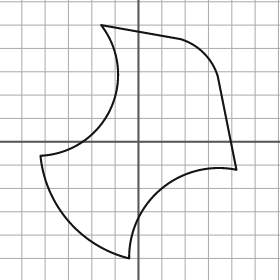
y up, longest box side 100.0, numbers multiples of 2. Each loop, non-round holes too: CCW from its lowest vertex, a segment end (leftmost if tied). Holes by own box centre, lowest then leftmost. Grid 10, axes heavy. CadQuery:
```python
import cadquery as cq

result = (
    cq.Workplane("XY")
    .moveTo(-4.0, -50.0)
    .threePointArc((10.0, -20.0), (42.0, -12.0))
    .lineTo(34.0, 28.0)
    .threePointArc((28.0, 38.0), (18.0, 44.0))
    .lineTo(-16.0, 50.0)
    .threePointArc((-12.0, 14.0), (-42.0, -6.0))
    .threePointArc((-30.0, -34.0), (-4.0, -50.0))
    .close()
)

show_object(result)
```